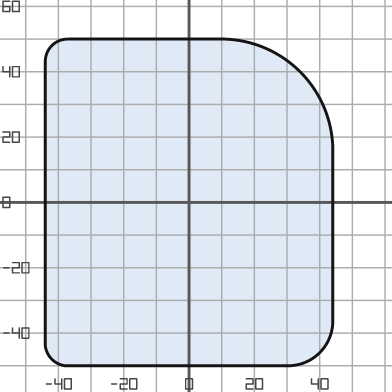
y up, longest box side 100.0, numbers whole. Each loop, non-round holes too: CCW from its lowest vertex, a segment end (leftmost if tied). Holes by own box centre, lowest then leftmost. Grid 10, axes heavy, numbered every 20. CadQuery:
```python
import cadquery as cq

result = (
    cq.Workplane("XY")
    .moveTo(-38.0, -50.0)
    .lineTo(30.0, -50.0)
    .threePointArc((40.0, -46.0), (44.0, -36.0))
    .lineTo(44.0, 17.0)
    .threePointArc((34.0, 40.0), (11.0, 50.0))
    .lineTo(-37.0, 50.0)
    .threePointArc((-42.0, 48.0), (-44.0, 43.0))
    .lineTo(-44.0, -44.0)
    .threePointArc((-42.0, -48.0), (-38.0, -50.0))
    .close()
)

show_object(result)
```